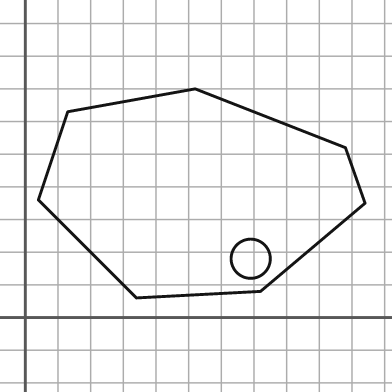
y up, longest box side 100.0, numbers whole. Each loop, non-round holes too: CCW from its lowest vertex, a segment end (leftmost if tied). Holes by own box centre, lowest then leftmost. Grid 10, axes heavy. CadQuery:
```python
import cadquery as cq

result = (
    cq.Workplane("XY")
    .moveTo(34.0, 6.0)
    .lineTo(72.0, 8.0)
    .lineTo(104.0, 35.0)
    .lineTo(98.0, 52.0)
    .lineTo(52.0, 70.0)
    .lineTo(13.0, 63.0)
    .lineTo(4.0, 36.0)
    .close()
    .moveTo(69.0, 18.0)
    .circle(6.0)
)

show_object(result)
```